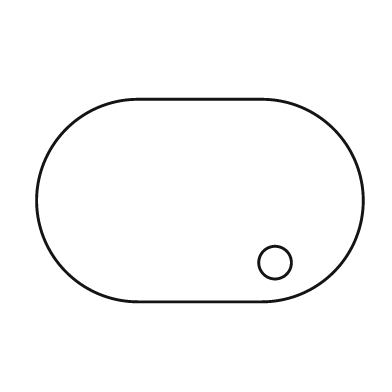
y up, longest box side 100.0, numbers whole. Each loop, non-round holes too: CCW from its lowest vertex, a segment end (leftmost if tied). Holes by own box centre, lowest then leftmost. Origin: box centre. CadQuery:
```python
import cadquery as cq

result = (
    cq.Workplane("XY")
    .moveTo(-19.0, -31.0)
    .lineTo(19.0, -31.0)
    .threePointArc((50.0, 0.0), (19.0, 31.0))
    .lineTo(-19.0, 31.0)
    .threePointArc((-50.0, 0.0), (-19.0, -31.0))
    .close()
    .moveTo(23.0, -19.0)
    .circle(5.0)
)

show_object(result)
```